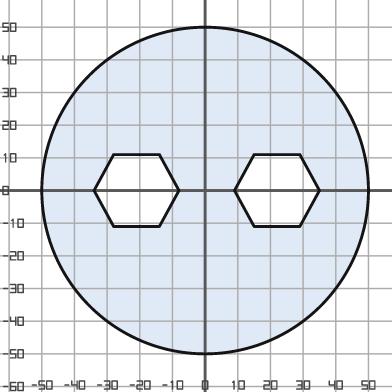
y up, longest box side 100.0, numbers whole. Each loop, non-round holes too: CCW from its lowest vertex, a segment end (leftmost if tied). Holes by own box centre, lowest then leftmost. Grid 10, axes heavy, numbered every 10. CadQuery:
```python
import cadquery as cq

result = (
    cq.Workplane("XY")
    .moveTo(0.0, 0.0)
    .circle(50.0)
    .moveTo(-28.0, -11.0)
    .lineTo(-14.0, -11.0)
    .lineTo(-8.0, 0.0)
    .lineTo(-14.0, 11.0)
    .lineTo(-28.0, 11.0)
    .lineTo(-34.0, 0.0)
    .close()
    .moveTo(15.0, -11.0)
    .lineTo(29.0, -11.0)
    .lineTo(35.0, 0.0)
    .lineTo(29.0, 11.0)
    .lineTo(15.0, 11.0)
    .lineTo(9.0, 0.0)
    .close()
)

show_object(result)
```